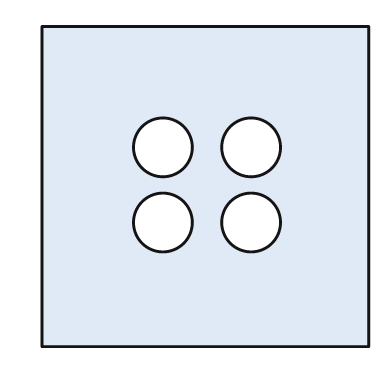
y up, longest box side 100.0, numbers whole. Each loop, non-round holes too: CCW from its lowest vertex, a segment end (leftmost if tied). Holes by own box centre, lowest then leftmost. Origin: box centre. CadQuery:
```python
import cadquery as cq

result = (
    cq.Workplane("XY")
    .moveTo(-50.0, -49.0)
    .lineTo(50.0, -49.0)
    .lineTo(50.0, 49.0)
    .lineTo(-50.0, 49.0)
    .close()
    .moveTo(-13.0, -11.0)
    .circle(9.0)
    .moveTo(14.0, -11.0)
    .circle(9.0)
    .moveTo(-13.0, 12.0)
    .circle(9.0)
    .moveTo(14.0, 12.0)
    .circle(9.0)
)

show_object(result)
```